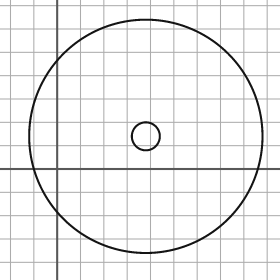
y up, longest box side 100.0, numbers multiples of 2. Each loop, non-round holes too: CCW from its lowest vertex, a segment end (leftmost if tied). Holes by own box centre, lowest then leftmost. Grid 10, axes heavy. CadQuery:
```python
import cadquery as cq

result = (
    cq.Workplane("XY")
    .moveTo(38.0, 14.0)
    .circle(50.0)
    .moveTo(38.0, 14.0)
    .circle(6.0)
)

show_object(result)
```